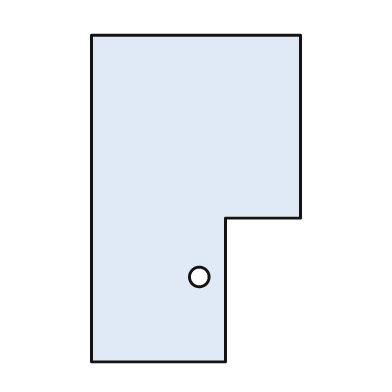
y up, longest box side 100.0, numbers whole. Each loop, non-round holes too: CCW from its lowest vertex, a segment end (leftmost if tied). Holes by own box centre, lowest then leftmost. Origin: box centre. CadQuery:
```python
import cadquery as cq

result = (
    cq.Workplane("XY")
    .moveTo(-32.0, -50.0)
    .lineTo(9.0, -50.0)
    .lineTo(9.0, -6.0)
    .lineTo(32.0, -6.0)
    .lineTo(32.0, 50.0)
    .lineTo(-32.0, 50.0)
    .close()
    .moveTo(1.0, -24.0)
    .circle(3.0)
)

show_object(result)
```